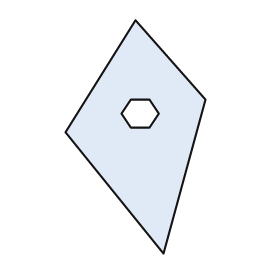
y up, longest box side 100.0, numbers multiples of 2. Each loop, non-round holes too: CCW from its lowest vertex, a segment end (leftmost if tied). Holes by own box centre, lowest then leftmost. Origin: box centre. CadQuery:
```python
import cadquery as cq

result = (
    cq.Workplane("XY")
    .moveTo(12.0, -50.0)
    .lineTo(30.0, 16.0)
    .lineTo(0.0, 50.0)
    .lineTo(-30.0, 2.0)
    .close()
    .moveTo(-2.0, 4.0)
    .lineTo(6.0, 4.0)
    .lineTo(10.0, 10.0)
    .lineTo(6.0, 16.0)
    .lineTo(-2.0, 16.0)
    .lineTo(-6.0, 10.0)
    .close()
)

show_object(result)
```